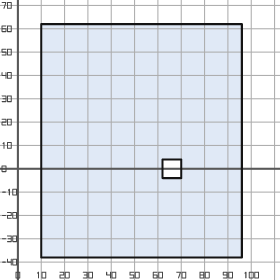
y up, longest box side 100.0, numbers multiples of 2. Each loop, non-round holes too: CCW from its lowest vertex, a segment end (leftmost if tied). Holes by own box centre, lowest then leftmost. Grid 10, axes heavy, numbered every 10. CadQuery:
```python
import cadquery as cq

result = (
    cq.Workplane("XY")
    .moveTo(10.0, -38.0)
    .lineTo(96.0, -38.0)
    .lineTo(96.0, 62.0)
    .lineTo(10.0, 62.0)
    .close()
    .moveTo(62.0, -4.0)
    .lineTo(70.0, -4.0)
    .lineTo(70.0, 4.0)
    .lineTo(62.0, 4.0)
    .close()
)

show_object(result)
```